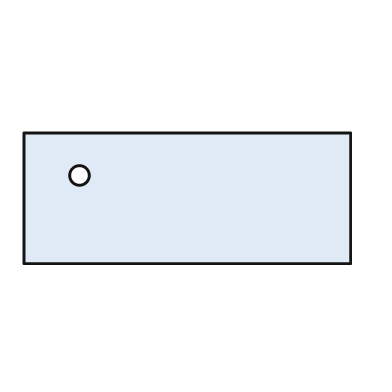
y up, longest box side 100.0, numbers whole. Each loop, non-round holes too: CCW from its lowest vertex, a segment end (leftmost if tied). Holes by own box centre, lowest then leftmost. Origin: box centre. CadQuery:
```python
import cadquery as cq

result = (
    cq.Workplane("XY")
    .moveTo(-50.0, -20.0)
    .lineTo(50.0, -20.0)
    .lineTo(50.0, 20.0)
    .lineTo(-50.0, 20.0)
    .close()
    .moveTo(-33.0, 7.0)
    .circle(3.0)
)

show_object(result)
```